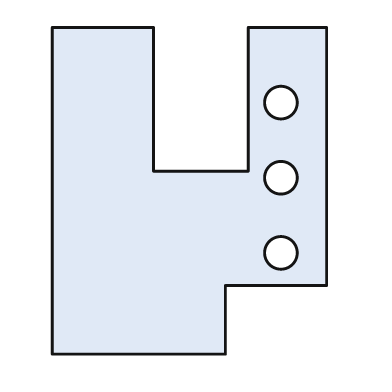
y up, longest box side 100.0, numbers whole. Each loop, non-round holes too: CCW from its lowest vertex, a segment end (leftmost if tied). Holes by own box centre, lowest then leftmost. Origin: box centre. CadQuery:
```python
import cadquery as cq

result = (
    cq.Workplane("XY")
    .moveTo(-42.0, -50.0)
    .lineTo(11.0, -50.0)
    .lineTo(11.0, -29.0)
    .lineTo(42.0, -29.0)
    .lineTo(42.0, 50.0)
    .lineTo(18.0, 50.0)
    .lineTo(18.0, 6.0)
    .lineTo(-11.0, 6.0)
    .lineTo(-11.0, 50.0)
    .lineTo(-42.0, 50.0)
    .close()
    .moveTo(28.0, -19.0)
    .circle(5.0)
    .moveTo(28.0, 4.0)
    .circle(5.0)
    .moveTo(28.0, 27.0)
    .circle(5.0)
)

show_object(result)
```